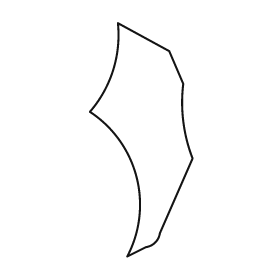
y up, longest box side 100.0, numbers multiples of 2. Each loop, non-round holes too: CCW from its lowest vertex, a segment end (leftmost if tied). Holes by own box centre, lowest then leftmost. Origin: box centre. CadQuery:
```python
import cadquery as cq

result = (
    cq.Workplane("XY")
    .moveTo(-6.0, -50.0)
    .lineTo(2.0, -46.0)
    .threePointArc((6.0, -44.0), (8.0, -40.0))
    .lineTo(22.0, -8.0)
    .threePointArc((18.0, 8.0), (18.0, 24.0))
    .lineTo(12.0, 38.0)
    .lineTo(-10.0, 50.0)
    .threePointArc((-12.0, 30.0), (-22.0, 12.0))
    .threePointArc((-2.0, -16.0), (-6.0, -50.0))
    .close()
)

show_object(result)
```